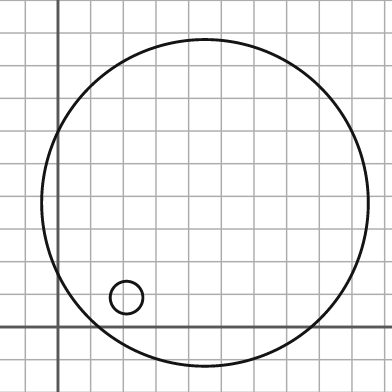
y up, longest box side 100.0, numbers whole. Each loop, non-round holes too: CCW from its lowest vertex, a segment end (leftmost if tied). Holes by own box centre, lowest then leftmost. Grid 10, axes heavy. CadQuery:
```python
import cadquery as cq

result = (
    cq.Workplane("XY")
    .moveTo(45.0, 38.0)
    .circle(50.0)
    .moveTo(21.0, 9.0)
    .circle(5.0)
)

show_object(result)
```